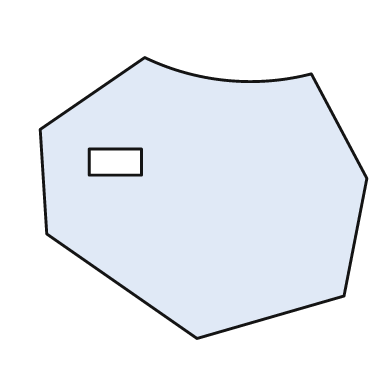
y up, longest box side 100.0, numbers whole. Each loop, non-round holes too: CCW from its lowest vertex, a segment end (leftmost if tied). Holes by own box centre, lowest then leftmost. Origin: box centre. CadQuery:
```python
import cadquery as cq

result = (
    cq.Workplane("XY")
    .moveTo(-2.0, -43.0)
    .lineTo(43.0, -30.0)
    .lineTo(50.0, 6.0)
    .lineTo(33.0, 38.0)
    .threePointArc((7.0, 36.0), (-18.0, 43.0))
    .lineTo(-50.0, 21.0)
    .lineTo(-48.0, -11.0)
    .close()
    .moveTo(-35.0, 7.0)
    .lineTo(-19.0, 7.0)
    .lineTo(-19.0, 15.0)
    .lineTo(-35.0, 15.0)
    .close()
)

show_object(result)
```